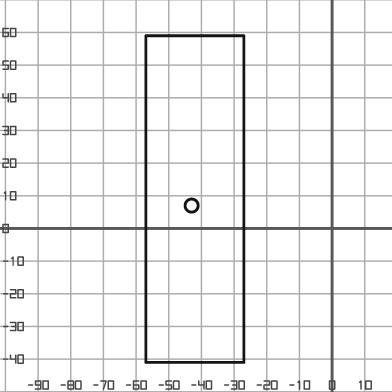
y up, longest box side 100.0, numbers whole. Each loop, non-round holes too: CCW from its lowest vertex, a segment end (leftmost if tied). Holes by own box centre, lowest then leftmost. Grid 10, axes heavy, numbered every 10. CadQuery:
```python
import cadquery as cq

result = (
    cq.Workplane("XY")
    .moveTo(-57.0, -41.0)
    .lineTo(-27.0, -41.0)
    .lineTo(-27.0, 59.0)
    .lineTo(-57.0, 59.0)
    .close()
    .moveTo(-43.0, 7.0)
    .circle(2.0)
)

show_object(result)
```